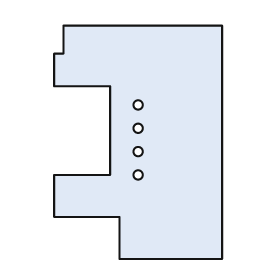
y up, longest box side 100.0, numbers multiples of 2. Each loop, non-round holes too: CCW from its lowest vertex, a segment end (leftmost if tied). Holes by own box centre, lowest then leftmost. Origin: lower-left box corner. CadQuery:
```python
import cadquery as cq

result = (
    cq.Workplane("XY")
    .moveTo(28.0, 0.0)
    .lineTo(72.0, 0.0)
    .lineTo(72.0, 100.0)
    .lineTo(4.0, 100.0)
    .lineTo(4.0, 88.0)
    .lineTo(0.0, 88.0)
    .lineTo(0.0, 74.0)
    .lineTo(24.0, 74.0)
    .lineTo(24.0, 36.0)
    .lineTo(0.0, 36.0)
    .lineTo(0.0, 18.0)
    .lineTo(28.0, 18.0)
    .close()
    .moveTo(36.0, 36.0)
    .circle(2.0)
    .moveTo(36.0, 46.0)
    .circle(2.0)
    .moveTo(36.0, 56.0)
    .circle(2.0)
    .moveTo(36.0, 66.0)
    .circle(2.0)
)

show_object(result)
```